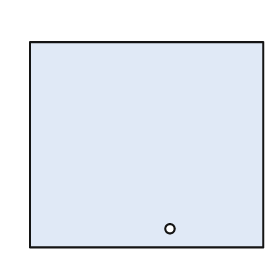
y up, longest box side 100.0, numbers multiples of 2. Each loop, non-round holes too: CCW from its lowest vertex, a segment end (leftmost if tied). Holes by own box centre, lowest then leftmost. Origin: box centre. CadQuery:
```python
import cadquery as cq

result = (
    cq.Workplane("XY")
    .moveTo(-50.0, -44.0)
    .lineTo(50.0, -44.0)
    .lineTo(50.0, 44.0)
    .lineTo(-50.0, 44.0)
    .close()
    .moveTo(10.0, -36.0)
    .circle(2.0)
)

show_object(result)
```